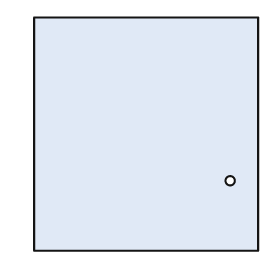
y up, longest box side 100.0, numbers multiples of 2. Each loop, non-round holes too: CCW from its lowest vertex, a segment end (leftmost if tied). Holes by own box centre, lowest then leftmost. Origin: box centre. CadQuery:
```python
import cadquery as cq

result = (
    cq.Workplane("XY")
    .moveTo(-48.0, -50.0)
    .lineTo(48.0, -50.0)
    .lineTo(48.0, 50.0)
    .lineTo(-48.0, 50.0)
    .close()
    .moveTo(36.0, -20.0)
    .circle(2.0)
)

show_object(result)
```